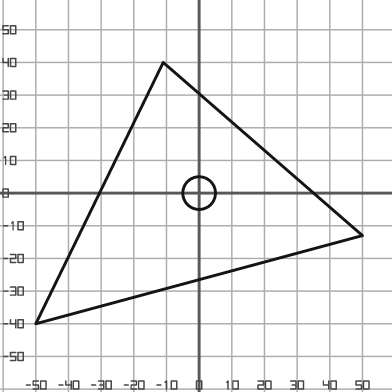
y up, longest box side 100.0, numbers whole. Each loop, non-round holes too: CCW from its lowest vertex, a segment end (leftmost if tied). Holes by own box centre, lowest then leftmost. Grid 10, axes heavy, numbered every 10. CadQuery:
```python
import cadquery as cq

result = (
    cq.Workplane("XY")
    .moveTo(-50.0, -40.0)
    .lineTo(50.0, -13.0)
    .lineTo(-11.0, 40.0)
    .close()
    .moveTo(0.0, 0.0)
    .circle(5.0)
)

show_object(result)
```